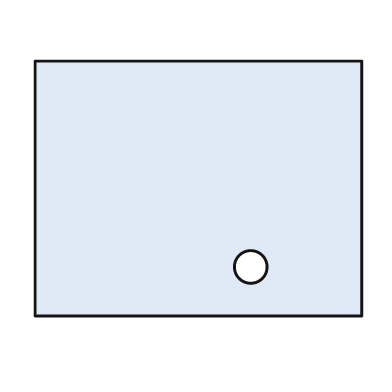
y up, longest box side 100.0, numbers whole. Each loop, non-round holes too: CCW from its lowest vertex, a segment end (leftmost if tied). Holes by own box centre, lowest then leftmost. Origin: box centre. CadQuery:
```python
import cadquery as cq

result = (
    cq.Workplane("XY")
    .moveTo(-50.0, -39.0)
    .lineTo(50.0, -39.0)
    .lineTo(50.0, 39.0)
    .lineTo(-50.0, 39.0)
    .close()
    .moveTo(16.0, -24.0)
    .circle(5.0)
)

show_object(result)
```